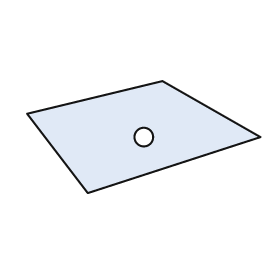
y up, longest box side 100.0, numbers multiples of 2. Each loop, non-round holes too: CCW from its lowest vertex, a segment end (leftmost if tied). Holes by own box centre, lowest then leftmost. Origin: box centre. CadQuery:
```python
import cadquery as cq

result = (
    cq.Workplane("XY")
    .moveTo(-24.0, -24.0)
    .lineTo(50.0, 0.0)
    .lineTo(8.0, 24.0)
    .lineTo(-50.0, 10.0)
    .close()
    .moveTo(0.0, 0.0)
    .circle(4.0)
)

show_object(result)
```